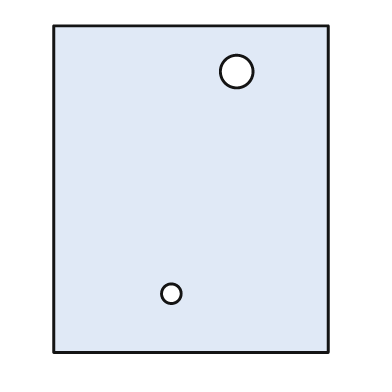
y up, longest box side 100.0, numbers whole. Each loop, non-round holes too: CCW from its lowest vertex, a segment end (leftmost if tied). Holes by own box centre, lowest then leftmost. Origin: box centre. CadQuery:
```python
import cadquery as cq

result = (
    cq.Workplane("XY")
    .moveTo(-42.0, -50.0)
    .lineTo(42.0, -50.0)
    .lineTo(42.0, 50.0)
    .lineTo(-42.0, 50.0)
    .close()
    .moveTo(-6.0, -32.0)
    .circle(3.0)
    .moveTo(14.0, 36.0)
    .circle(5.0)
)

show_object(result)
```